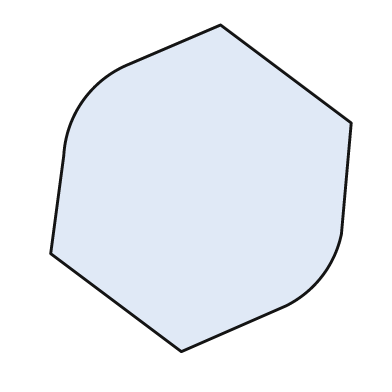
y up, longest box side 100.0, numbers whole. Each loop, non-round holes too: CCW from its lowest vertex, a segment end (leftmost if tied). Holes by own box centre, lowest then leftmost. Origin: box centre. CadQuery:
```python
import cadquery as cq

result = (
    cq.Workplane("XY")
    .moveTo(-6.0, -50.0)
    .lineTo(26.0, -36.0)
    .threePointArc((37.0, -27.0), (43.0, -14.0))
    .lineTo(46.0, 20.0)
    .lineTo(6.0, 50.0)
    .lineTo(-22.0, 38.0)
    .threePointArc((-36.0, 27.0), (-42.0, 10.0))
    .lineTo(-46.0, -20.0)
    .close()
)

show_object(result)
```